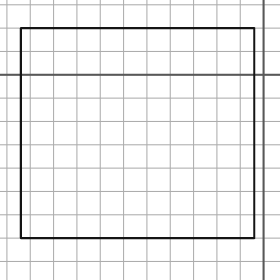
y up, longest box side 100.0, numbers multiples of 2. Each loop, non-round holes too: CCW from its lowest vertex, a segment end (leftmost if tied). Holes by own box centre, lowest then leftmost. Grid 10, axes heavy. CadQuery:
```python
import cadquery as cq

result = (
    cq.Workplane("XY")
    .moveTo(-104.0, -70.0)
    .lineTo(-4.0, -70.0)
    .lineTo(-4.0, 20.0)
    .lineTo(-104.0, 20.0)
    .close()
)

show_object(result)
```